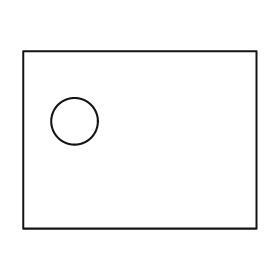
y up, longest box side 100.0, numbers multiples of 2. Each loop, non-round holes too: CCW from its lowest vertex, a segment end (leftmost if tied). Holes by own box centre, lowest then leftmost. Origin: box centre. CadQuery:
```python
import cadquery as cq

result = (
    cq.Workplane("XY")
    .moveTo(-50.0, -38.0)
    .lineTo(50.0, -38.0)
    .lineTo(50.0, 38.0)
    .lineTo(-50.0, 38.0)
    .close()
    .moveTo(-28.0, 8.0)
    .circle(10.0)
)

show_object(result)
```